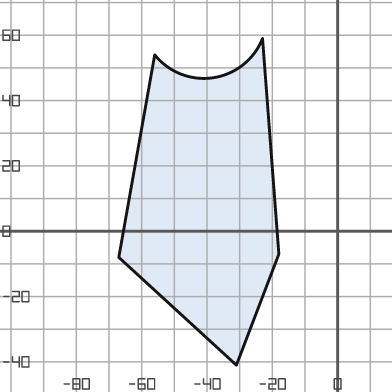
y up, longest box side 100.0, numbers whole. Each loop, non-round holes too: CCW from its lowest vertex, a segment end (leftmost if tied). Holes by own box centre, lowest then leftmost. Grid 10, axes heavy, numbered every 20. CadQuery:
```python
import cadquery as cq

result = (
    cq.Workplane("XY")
    .moveTo(-31.0, -41.0)
    .lineTo(-18.0, -7.0)
    .lineTo(-23.0, 59.0)
    .threePointArc((-38.0, 47.0), (-56.0, 54.0))
    .lineTo(-67.0, -8.0)
    .close()
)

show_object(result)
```